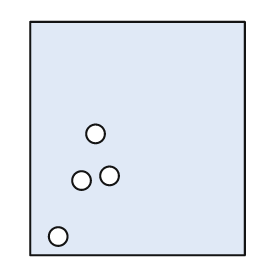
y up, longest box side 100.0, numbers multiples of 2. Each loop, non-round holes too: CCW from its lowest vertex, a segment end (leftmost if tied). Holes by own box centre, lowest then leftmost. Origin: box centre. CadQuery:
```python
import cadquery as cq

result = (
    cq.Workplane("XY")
    .moveTo(-46.0, -50.0)
    .lineTo(46.0, -50.0)
    .lineTo(46.0, 50.0)
    .lineTo(-46.0, 50.0)
    .close()
    .moveTo(-34.0, -42.0)
    .circle(4.0)
    .moveTo(-24.0, -18.0)
    .circle(4.0)
    .moveTo(-12.0, -16.0)
    .circle(4.0)
    .moveTo(-18.0, 2.0)
    .circle(4.0)
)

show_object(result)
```